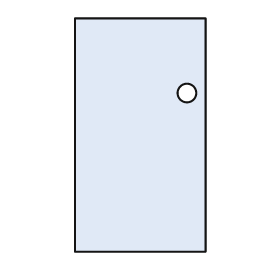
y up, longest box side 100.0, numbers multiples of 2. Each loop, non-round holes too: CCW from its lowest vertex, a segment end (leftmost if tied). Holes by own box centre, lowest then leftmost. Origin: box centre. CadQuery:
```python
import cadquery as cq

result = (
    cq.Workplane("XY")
    .moveTo(-28.0, -50.0)
    .lineTo(28.0, -50.0)
    .lineTo(28.0, 50.0)
    .lineTo(-28.0, 50.0)
    .close()
    .moveTo(20.0, 18.0)
    .circle(4.0)
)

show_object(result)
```